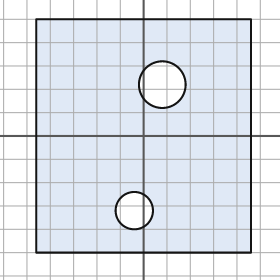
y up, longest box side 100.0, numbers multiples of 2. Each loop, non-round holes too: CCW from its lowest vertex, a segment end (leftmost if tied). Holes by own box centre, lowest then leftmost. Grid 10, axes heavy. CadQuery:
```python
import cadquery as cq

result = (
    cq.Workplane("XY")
    .moveTo(-46.0, -50.0)
    .lineTo(46.0, -50.0)
    .lineTo(46.0, 50.0)
    .lineTo(-46.0, 50.0)
    .close()
    .moveTo(-4.0, -32.0)
    .circle(8.0)
    .moveTo(8.0, 22.0)
    .circle(10.0)
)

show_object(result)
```